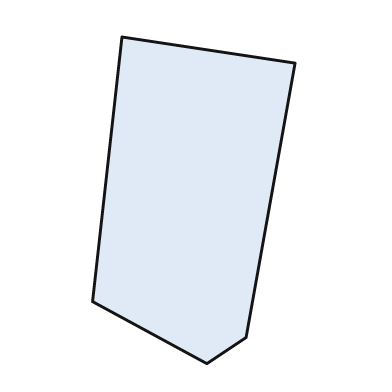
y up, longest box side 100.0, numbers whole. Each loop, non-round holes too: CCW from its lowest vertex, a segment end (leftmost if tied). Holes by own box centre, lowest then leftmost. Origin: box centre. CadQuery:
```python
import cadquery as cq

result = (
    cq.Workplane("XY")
    .moveTo(4.0, -50.0)
    .lineTo(16.0, -42.0)
    .lineTo(31.0, 42.0)
    .lineTo(-22.0, 50.0)
    .lineTo(-31.0, -31.0)
    .close()
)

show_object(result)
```